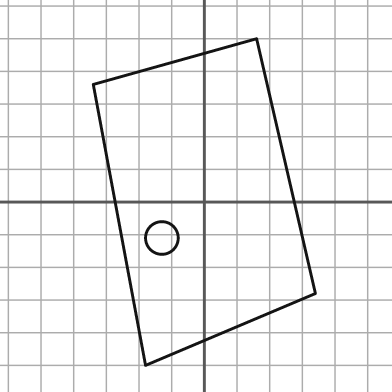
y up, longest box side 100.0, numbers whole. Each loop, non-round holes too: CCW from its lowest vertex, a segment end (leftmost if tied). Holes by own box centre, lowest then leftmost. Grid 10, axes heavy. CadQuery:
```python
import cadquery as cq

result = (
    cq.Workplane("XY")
    .moveTo(-18.0, -50.0)
    .lineTo(34.0, -28.0)
    .lineTo(16.0, 50.0)
    .lineTo(-34.0, 36.0)
    .close()
    .moveTo(-13.0, -11.0)
    .circle(5.0)
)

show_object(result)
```